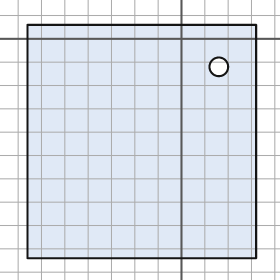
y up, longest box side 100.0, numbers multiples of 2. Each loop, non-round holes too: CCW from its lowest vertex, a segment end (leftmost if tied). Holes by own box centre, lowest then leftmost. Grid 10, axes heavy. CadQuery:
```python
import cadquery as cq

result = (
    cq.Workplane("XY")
    .moveTo(-66.0, -94.0)
    .lineTo(32.0, -94.0)
    .lineTo(32.0, 6.0)
    .lineTo(-66.0, 6.0)
    .close()
    .moveTo(16.0, -12.0)
    .circle(4.0)
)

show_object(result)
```